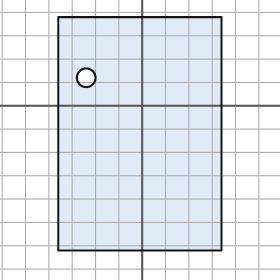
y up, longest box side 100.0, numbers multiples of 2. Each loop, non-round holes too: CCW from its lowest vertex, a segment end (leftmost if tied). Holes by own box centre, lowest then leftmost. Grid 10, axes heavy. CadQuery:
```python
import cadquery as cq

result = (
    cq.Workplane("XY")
    .moveTo(-36.0, -62.0)
    .lineTo(34.0, -62.0)
    .lineTo(34.0, 38.0)
    .lineTo(-36.0, 38.0)
    .close()
    .moveTo(-24.0, 12.0)
    .circle(4.0)
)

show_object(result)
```